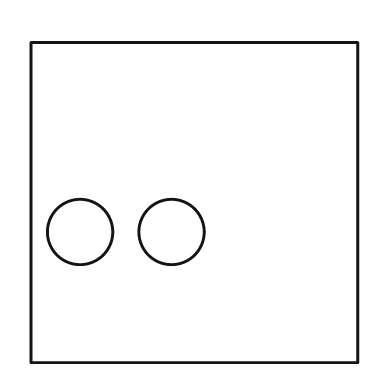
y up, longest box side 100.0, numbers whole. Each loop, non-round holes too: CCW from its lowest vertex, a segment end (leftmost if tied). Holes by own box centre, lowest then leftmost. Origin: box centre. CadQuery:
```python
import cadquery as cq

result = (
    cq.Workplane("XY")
    .moveTo(-50.0, -49.0)
    .lineTo(50.0, -49.0)
    .lineTo(50.0, 49.0)
    .lineTo(-50.0, 49.0)
    .close()
    .moveTo(-35.0, -9.0)
    .circle(10.0)
    .moveTo(-7.0, -9.0)
    .circle(10.0)
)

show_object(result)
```